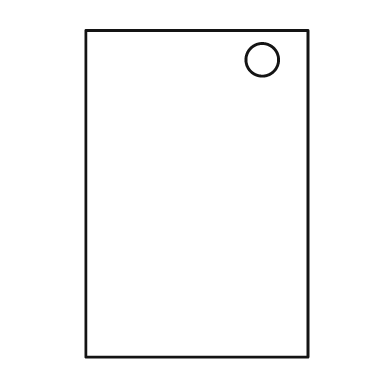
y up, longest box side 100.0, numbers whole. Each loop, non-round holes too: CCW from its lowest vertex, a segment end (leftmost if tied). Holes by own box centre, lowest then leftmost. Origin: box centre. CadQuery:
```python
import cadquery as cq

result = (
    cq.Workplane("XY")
    .moveTo(-34.0, -50.0)
    .lineTo(34.0, -50.0)
    .lineTo(34.0, 50.0)
    .lineTo(-34.0, 50.0)
    .close()
    .moveTo(20.0, 41.0)
    .circle(5.0)
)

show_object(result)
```